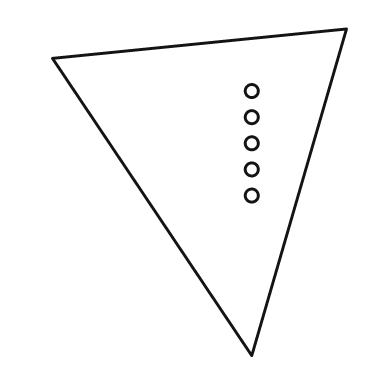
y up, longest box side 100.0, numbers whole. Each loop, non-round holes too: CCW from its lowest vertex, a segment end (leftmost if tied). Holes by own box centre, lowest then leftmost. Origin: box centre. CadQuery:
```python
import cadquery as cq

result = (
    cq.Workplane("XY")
    .moveTo(16.0, -50.0)
    .lineTo(45.0, 50.0)
    .lineTo(-45.0, 41.0)
    .close()
    .moveTo(16.0, -1.0)
    .circle(2.0)
    .moveTo(16.0, 7.0)
    .circle(2.0)
    .moveTo(16.0, 15.0)
    .circle(2.0)
    .moveTo(16.0, 23.0)
    .circle(2.0)
    .moveTo(16.0, 31.0)
    .circle(2.0)
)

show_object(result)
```